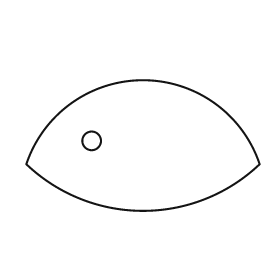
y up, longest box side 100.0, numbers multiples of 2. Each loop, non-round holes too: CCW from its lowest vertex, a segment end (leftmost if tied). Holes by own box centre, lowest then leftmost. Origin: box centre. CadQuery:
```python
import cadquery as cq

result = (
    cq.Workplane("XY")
    .moveTo(-50.0, -8.0)
    .threePointArc((0.0, -28.0), (50.0, -8.0))
    .threePointArc((0.0, 28.0), (-50.0, -8.0))
    .close()
    .moveTo(-22.0, 2.0)
    .circle(4.0)
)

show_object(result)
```